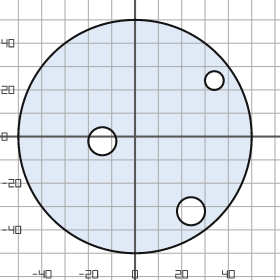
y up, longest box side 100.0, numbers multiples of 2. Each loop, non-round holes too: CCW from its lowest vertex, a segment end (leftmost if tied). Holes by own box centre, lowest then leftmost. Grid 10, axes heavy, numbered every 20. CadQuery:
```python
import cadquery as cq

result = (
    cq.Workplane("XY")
    .moveTo(0.0, 0.0)
    .circle(50.0)
    .moveTo(24.0, -32.0)
    .circle(6.0)
    .moveTo(-14.0, -2.0)
    .circle(6.0)
    .moveTo(34.0, 24.0)
    .circle(4.0)
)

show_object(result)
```